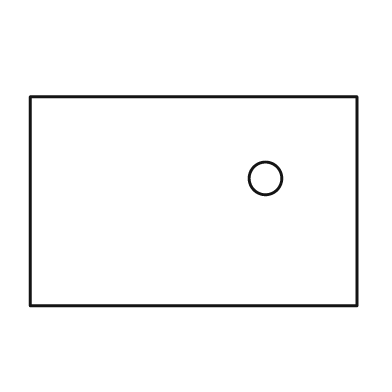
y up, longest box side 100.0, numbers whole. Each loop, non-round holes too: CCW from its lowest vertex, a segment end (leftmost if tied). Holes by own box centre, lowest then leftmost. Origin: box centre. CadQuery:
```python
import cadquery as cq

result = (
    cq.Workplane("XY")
    .moveTo(-50.0, -32.0)
    .lineTo(50.0, -32.0)
    .lineTo(50.0, 32.0)
    .lineTo(-50.0, 32.0)
    .close()
    .moveTo(22.0, 7.0)
    .circle(5.0)
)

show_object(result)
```